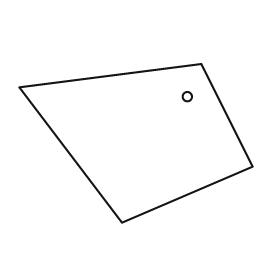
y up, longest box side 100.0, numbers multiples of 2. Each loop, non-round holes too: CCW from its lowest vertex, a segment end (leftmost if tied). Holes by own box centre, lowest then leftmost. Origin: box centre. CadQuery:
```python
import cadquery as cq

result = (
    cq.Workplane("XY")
    .moveTo(-6.0, -34.0)
    .lineTo(50.0, -10.0)
    .lineTo(28.0, 34.0)
    .lineTo(-50.0, 24.0)
    .close()
    .moveTo(22.0, 20.0)
    .circle(2.0)
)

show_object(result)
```